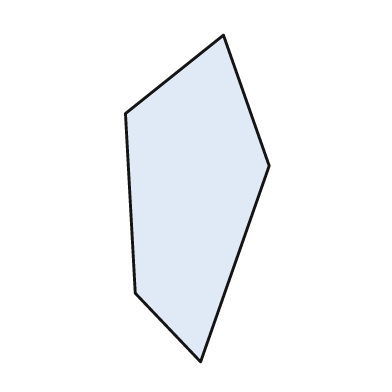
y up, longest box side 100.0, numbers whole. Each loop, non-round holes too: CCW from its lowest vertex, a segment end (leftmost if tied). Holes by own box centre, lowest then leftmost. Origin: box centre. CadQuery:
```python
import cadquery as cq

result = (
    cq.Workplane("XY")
    .moveTo(1.0, -50.0)
    .lineTo(22.0, 10.0)
    .lineTo(8.0, 50.0)
    .lineTo(-22.0, 26.0)
    .lineTo(-19.0, -29.0)
    .close()
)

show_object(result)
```